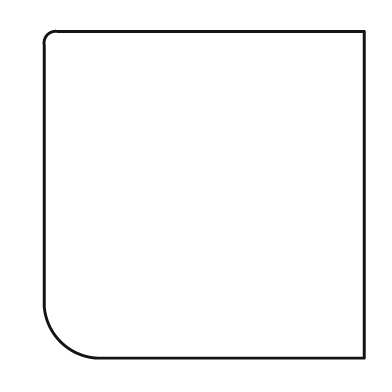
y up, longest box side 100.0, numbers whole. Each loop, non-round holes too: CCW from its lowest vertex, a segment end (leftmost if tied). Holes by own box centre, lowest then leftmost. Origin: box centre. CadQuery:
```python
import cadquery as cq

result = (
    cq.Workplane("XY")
    .moveTo(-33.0, -50.0)
    .lineTo(49.0, -50.0)
    .lineTo(49.0, 50.0)
    .lineTo(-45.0, 50.0)
    .threePointArc((-48.0, 49.0), (-49.0, 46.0))
    .lineTo(-49.0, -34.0)
    .threePointArc((-44.0, -45.0), (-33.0, -50.0))
    .close()
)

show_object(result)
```